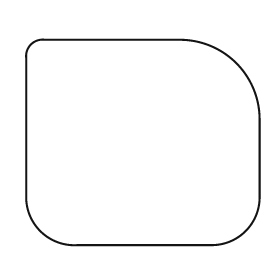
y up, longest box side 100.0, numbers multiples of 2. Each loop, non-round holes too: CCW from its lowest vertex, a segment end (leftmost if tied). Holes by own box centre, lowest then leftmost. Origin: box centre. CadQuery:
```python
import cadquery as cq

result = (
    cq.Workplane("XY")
    .moveTo(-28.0, -44.0)
    .lineTo(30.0, -44.0)
    .threePointArc((44.0, -38.0), (50.0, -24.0))
    .lineTo(50.0, 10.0)
    .threePointArc((40.0, 34.0), (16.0, 44.0))
    .lineTo(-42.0, 44.0)
    .threePointArc((-48.0, 42.0), (-50.0, 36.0))
    .lineTo(-50.0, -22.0)
    .threePointArc((-44.0, -38.0), (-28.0, -44.0))
    .close()
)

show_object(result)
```